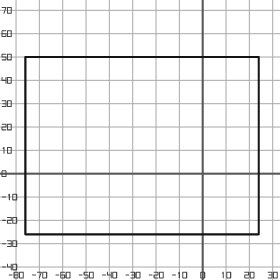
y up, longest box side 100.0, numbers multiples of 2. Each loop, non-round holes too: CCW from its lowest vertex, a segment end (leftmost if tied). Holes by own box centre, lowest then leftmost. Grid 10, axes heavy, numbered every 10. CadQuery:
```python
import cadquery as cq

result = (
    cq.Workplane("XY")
    .moveTo(-76.0, -26.0)
    .lineTo(24.0, -26.0)
    .lineTo(24.0, 50.0)
    .lineTo(-76.0, 50.0)
    .close()
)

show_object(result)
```